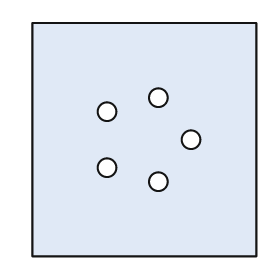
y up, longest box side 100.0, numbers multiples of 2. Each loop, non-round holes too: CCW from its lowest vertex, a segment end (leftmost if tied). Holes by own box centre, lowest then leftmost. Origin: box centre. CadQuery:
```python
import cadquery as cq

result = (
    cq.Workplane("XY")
    .moveTo(-48.0, -50.0)
    .lineTo(48.0, -50.0)
    .lineTo(48.0, 50.0)
    .lineTo(-48.0, 50.0)
    .close()
    .moveTo(6.0, -18.0)
    .circle(4.0)
    .moveTo(-16.0, -12.0)
    .circle(4.0)
    .moveTo(20.0, 0.0)
    .circle(4.0)
    .moveTo(-16.0, 12.0)
    .circle(4.0)
    .moveTo(6.0, 18.0)
    .circle(4.0)
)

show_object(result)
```